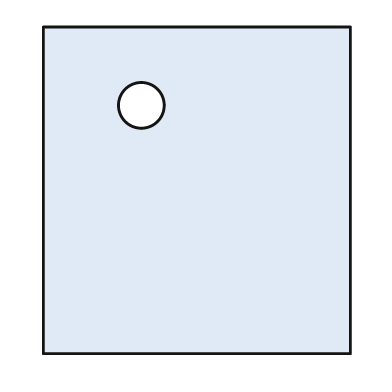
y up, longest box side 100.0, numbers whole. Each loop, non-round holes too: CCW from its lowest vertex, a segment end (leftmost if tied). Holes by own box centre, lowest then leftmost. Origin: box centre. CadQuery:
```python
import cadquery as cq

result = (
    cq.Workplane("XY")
    .moveTo(-47.0, -50.0)
    .lineTo(47.0, -50.0)
    .lineTo(47.0, 50.0)
    .lineTo(-47.0, 50.0)
    .close()
    .moveTo(-17.0, 26.0)
    .circle(7.0)
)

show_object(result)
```